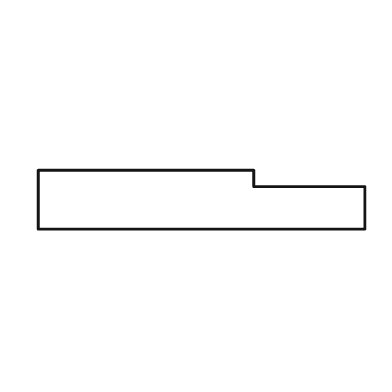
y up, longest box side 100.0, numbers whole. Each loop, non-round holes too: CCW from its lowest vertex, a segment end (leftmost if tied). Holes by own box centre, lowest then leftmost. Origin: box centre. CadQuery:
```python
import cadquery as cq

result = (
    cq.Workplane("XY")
    .moveTo(-50.0, -9.0)
    .lineTo(50.0, -9.0)
    .lineTo(50.0, 4.0)
    .lineTo(16.0, 4.0)
    .lineTo(16.0, 9.0)
    .lineTo(-50.0, 9.0)
    .close()
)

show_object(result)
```